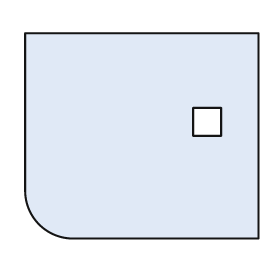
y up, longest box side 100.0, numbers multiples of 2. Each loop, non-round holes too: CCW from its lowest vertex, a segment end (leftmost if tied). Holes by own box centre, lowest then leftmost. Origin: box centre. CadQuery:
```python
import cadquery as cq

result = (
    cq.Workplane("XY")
    .moveTo(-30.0, -44.0)
    .lineTo(50.0, -44.0)
    .lineTo(50.0, 44.0)
    .lineTo(-50.0, 44.0)
    .lineTo(-50.0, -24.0)
    .threePointArc((-44.0, -38.0), (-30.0, -44.0))
    .close()
    .moveTo(22.0, 0.0)
    .lineTo(34.0, 0.0)
    .lineTo(34.0, 12.0)
    .lineTo(22.0, 12.0)
    .close()
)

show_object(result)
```